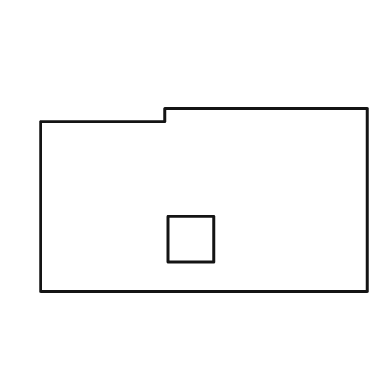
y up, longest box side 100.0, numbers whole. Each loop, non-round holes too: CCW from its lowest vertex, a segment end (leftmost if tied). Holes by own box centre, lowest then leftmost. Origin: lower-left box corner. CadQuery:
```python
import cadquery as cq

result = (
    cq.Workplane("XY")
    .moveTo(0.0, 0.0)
    .lineTo(100.0, 0.0)
    .lineTo(100.0, 56.0)
    .lineTo(38.0, 56.0)
    .lineTo(38.0, 52.0)
    .lineTo(0.0, 52.0)
    .close()
    .moveTo(39.0, 9.0)
    .lineTo(53.0, 9.0)
    .lineTo(53.0, 23.0)
    .lineTo(39.0, 23.0)
    .close()
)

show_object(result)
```